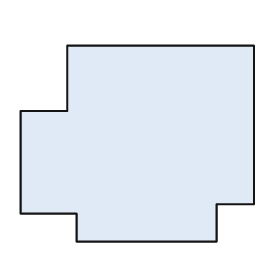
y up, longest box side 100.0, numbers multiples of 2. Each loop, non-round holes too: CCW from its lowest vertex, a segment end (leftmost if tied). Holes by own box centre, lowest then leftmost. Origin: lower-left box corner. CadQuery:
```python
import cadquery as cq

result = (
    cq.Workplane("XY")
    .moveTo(24.0, 0.0)
    .lineTo(84.0, 0.0)
    .lineTo(84.0, 16.0)
    .lineTo(100.0, 16.0)
    .lineTo(100.0, 84.0)
    .lineTo(20.0, 84.0)
    .lineTo(20.0, 56.0)
    .lineTo(0.0, 56.0)
    .lineTo(0.0, 12.0)
    .lineTo(24.0, 12.0)
    .close()
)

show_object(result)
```